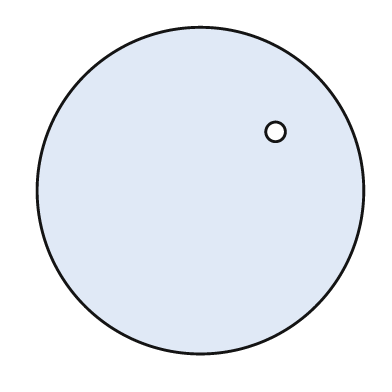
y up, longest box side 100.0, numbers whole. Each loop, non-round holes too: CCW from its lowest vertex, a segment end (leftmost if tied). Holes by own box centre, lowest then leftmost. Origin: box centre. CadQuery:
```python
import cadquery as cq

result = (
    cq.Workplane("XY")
    .moveTo(0.0, 0.0)
    .circle(50.0)
    .moveTo(23.0, 18.0)
    .circle(3.0)
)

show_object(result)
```